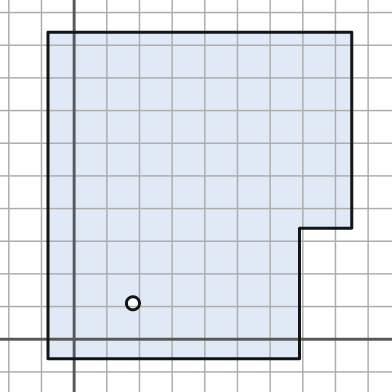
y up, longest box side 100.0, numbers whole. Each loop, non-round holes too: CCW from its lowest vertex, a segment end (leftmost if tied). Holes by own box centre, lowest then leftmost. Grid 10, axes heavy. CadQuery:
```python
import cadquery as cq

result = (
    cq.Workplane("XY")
    .moveTo(-8.0, -6.0)
    .lineTo(69.0, -6.0)
    .lineTo(69.0, 34.0)
    .lineTo(85.0, 34.0)
    .lineTo(85.0, 94.0)
    .lineTo(-8.0, 94.0)
    .close()
    .moveTo(18.0, 11.0)
    .circle(2.0)
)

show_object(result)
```